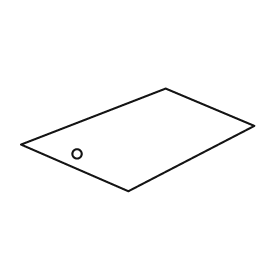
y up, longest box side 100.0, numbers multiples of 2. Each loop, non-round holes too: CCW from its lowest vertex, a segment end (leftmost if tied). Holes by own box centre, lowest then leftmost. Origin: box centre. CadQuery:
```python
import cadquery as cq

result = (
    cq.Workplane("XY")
    .moveTo(-4.0, -22.0)
    .lineTo(50.0, 6.0)
    .lineTo(12.0, 22.0)
    .lineTo(-50.0, -2.0)
    .close()
    .moveTo(-26.0, -6.0)
    .circle(2.0)
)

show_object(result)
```